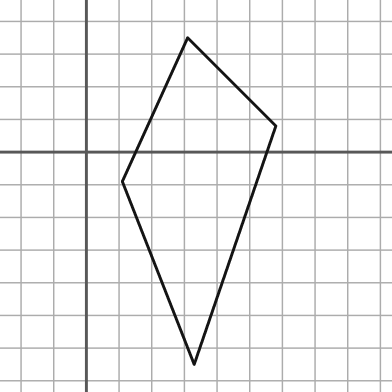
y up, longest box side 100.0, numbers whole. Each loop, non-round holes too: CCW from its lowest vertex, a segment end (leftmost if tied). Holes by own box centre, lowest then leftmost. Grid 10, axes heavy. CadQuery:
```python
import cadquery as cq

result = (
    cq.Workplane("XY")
    .moveTo(33.0, -65.0)
    .lineTo(58.0, 8.0)
    .lineTo(31.0, 35.0)
    .lineTo(11.0, -9.0)
    .close()
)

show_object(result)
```